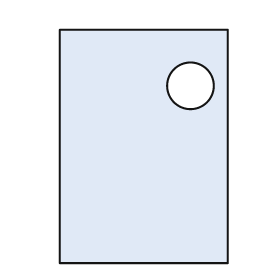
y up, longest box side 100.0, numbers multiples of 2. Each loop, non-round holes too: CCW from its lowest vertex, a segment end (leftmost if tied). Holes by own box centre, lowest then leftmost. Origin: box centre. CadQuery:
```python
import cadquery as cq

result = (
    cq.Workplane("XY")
    .moveTo(-36.0, -50.0)
    .lineTo(36.0, -50.0)
    .lineTo(36.0, 50.0)
    .lineTo(-36.0, 50.0)
    .close()
    .moveTo(20.0, 26.0)
    .circle(10.0)
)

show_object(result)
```